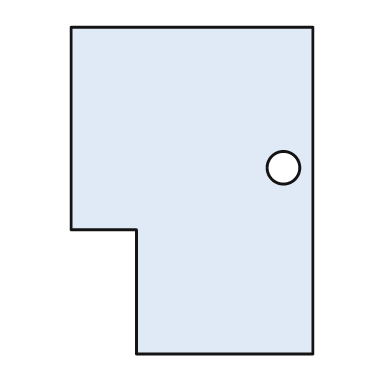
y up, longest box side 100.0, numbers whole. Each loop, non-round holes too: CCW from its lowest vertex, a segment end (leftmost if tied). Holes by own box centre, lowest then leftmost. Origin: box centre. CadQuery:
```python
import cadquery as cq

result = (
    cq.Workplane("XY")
    .moveTo(-17.0, -50.0)
    .lineTo(37.0, -50.0)
    .lineTo(37.0, 50.0)
    .lineTo(-37.0, 50.0)
    .lineTo(-37.0, -12.0)
    .lineTo(-17.0, -12.0)
    .close()
    .moveTo(28.0, 7.0)
    .circle(5.0)
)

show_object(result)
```